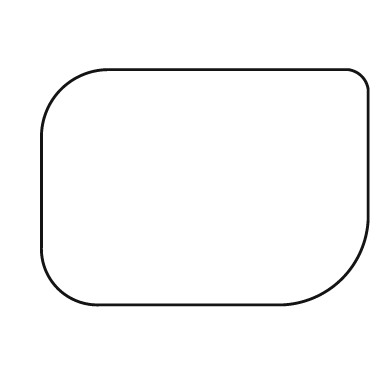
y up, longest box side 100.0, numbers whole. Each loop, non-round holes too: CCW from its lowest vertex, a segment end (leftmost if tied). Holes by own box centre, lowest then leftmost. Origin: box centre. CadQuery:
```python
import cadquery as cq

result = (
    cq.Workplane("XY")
    .moveTo(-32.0, -36.0)
    .lineTo(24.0, -36.0)
    .threePointArc((42.0, -28.0), (50.0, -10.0))
    .lineTo(50.0, 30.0)
    .threePointArc((48.0, 34.0), (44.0, 36.0))
    .lineTo(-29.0, 36.0)
    .threePointArc((-44.0, 30.0), (-50.0, 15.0))
    .lineTo(-50.0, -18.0)
    .threePointArc((-45.0, -31.0), (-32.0, -36.0))
    .close()
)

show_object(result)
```